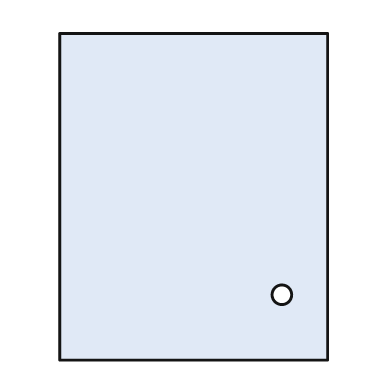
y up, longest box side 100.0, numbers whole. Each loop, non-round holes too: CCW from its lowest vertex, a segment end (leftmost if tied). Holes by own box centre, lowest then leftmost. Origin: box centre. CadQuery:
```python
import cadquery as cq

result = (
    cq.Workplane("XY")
    .moveTo(-41.0, -50.0)
    .lineTo(41.0, -50.0)
    .lineTo(41.0, 50.0)
    .lineTo(-41.0, 50.0)
    .close()
    .moveTo(27.0, -30.0)
    .circle(3.0)
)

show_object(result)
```